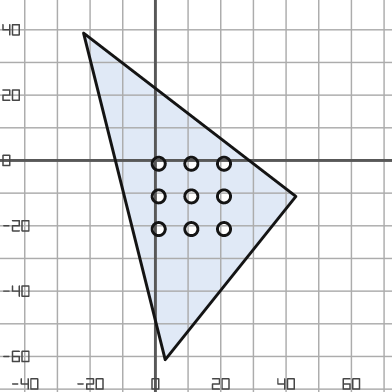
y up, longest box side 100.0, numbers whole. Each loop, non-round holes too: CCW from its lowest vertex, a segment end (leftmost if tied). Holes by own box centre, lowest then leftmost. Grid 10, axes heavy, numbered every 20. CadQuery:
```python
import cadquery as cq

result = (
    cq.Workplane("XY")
    .moveTo(3.0, -61.0)
    .lineTo(43.0, -11.0)
    .lineTo(-22.0, 39.0)
    .close()
    .moveTo(1.0, -21.0)
    .circle(2.0)
    .moveTo(11.0, -21.0)
    .circle(2.0)
    .moveTo(21.0, -21.0)
    .circle(2.0)
    .moveTo(1.0, -11.0)
    .circle(2.0)
    .moveTo(11.0, -11.0)
    .circle(2.0)
    .moveTo(21.0, -11.0)
    .circle(2.0)
    .moveTo(1.0, -1.0)
    .circle(2.0)
    .moveTo(11.0, -1.0)
    .circle(2.0)
    .moveTo(21.0, -1.0)
    .circle(2.0)
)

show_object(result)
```